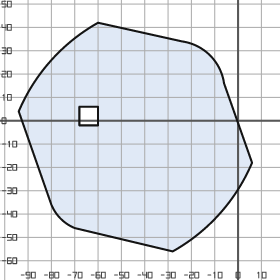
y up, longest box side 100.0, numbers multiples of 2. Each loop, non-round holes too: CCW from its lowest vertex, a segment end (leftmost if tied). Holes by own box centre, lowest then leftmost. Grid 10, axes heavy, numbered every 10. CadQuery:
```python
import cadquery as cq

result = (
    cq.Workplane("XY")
    .moveTo(-28.0, -56.0)
    .threePointArc((-8.0, -40.0), (6.0, -18.0))
    .lineTo(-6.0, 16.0)
    .threePointArc((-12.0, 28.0), (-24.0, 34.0))
    .lineTo(-60.0, 42.0)
    .threePointArc((-80.0, 26.0), (-94.0, 4.0))
    .lineTo(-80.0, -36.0)
    .threePointArc((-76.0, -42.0), (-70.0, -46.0))
    .close()
    .moveTo(-68.0, -2.0)
    .lineTo(-60.0, -2.0)
    .lineTo(-60.0, 6.0)
    .lineTo(-68.0, 6.0)
    .close()
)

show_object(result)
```